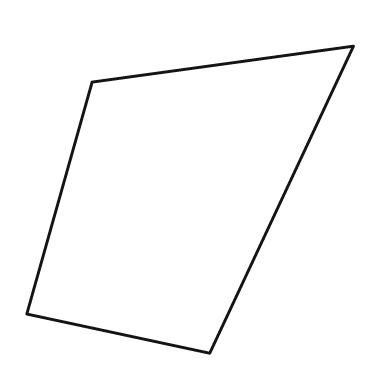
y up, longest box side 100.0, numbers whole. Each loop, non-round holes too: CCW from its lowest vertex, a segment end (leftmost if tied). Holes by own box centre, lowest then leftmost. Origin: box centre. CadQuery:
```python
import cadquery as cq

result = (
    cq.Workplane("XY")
    .moveTo(6.0, -47.0)
    .lineTo(50.0, 47.0)
    .lineTo(-30.0, 36.0)
    .lineTo(-50.0, -35.0)
    .close()
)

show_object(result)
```